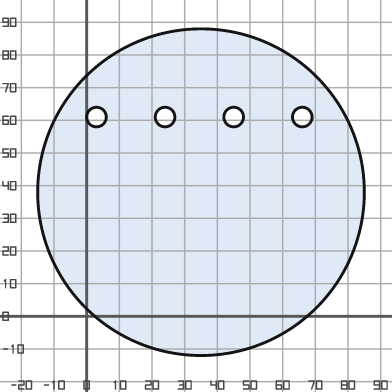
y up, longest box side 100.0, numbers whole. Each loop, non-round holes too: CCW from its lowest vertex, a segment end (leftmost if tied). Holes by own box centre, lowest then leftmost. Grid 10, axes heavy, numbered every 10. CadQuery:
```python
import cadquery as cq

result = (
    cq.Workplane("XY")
    .moveTo(35.0, 38.0)
    .circle(50.0)
    .moveTo(3.0, 61.0)
    .circle(3.0)
    .moveTo(24.0, 61.0)
    .circle(3.0)
    .moveTo(45.0, 61.0)
    .circle(3.0)
    .moveTo(66.0, 61.0)
    .circle(3.0)
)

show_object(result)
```